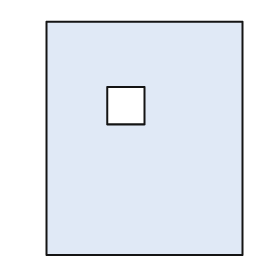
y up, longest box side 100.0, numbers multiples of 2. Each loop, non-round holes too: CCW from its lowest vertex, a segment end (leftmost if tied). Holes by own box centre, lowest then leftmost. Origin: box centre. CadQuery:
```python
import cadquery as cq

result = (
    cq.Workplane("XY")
    .moveTo(-42.0, -50.0)
    .lineTo(42.0, -50.0)
    .lineTo(42.0, 50.0)
    .lineTo(-42.0, 50.0)
    .close()
    .moveTo(-16.0, 6.0)
    .lineTo(0.0, 6.0)
    .lineTo(0.0, 22.0)
    .lineTo(-16.0, 22.0)
    .close()
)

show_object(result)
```